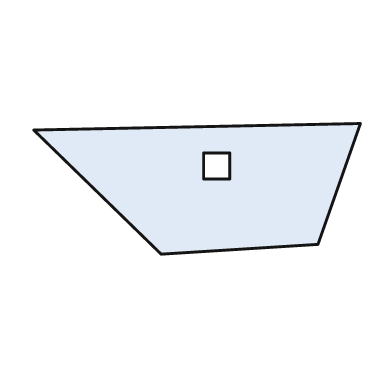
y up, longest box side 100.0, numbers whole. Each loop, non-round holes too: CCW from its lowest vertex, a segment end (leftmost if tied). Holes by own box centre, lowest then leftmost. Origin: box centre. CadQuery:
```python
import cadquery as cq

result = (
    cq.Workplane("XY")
    .moveTo(-11.0, -20.0)
    .lineTo(37.0, -17.0)
    .lineTo(50.0, 20.0)
    .lineTo(-50.0, 18.0)
    .close()
    .moveTo(2.0, 3.0)
    .lineTo(10.0, 3.0)
    .lineTo(10.0, 11.0)
    .lineTo(2.0, 11.0)
    .close()
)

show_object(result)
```